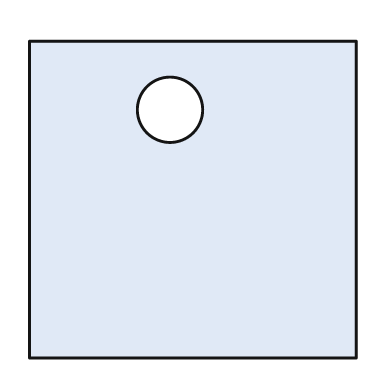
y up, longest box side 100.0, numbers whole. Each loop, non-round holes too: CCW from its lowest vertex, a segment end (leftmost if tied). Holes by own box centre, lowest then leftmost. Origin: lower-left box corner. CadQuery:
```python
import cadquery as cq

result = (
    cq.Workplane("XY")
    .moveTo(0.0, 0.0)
    .lineTo(100.0, 0.0)
    .lineTo(100.0, 97.0)
    .lineTo(0.0, 97.0)
    .close()
    .moveTo(43.0, 76.0)
    .circle(10.0)
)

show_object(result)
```